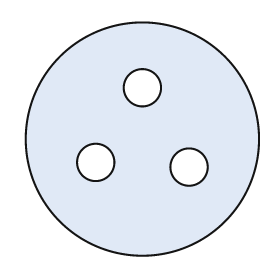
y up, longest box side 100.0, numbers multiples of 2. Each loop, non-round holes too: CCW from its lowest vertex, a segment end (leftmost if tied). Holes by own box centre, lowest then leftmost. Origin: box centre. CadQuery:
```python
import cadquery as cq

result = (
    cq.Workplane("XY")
    .moveTo(0.0, 0.0)
    .circle(50.0)
    .moveTo(20.0, -12.0)
    .circle(8.0)
    .moveTo(-20.0, -10.0)
    .circle(8.0)
    .moveTo(0.0, 22.0)
    .circle(8.0)
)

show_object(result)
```